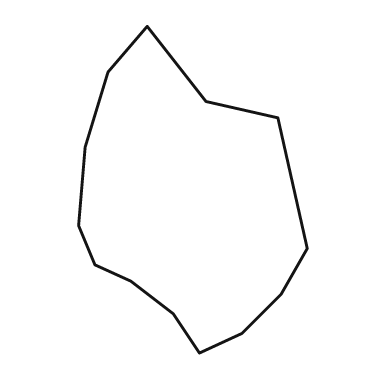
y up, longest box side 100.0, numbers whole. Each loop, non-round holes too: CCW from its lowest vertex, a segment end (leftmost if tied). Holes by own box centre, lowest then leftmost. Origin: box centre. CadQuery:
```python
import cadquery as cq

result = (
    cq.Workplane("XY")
    .moveTo(2.0, -50.0)
    .lineTo(15.0, -44.0)
    .lineTo(27.0, -32.0)
    .lineTo(35.0, -18.0)
    .lineTo(26.0, 22.0)
    .lineTo(4.0, 27.0)
    .lineTo(-14.0, 50.0)
    .lineTo(-26.0, 36.0)
    .lineTo(-33.0, 13.0)
    .lineTo(-35.0, -11.0)
    .lineTo(-30.0, -23.0)
    .lineTo(-19.0, -28.0)
    .lineTo(-6.0, -38.0)
    .close()
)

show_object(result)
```